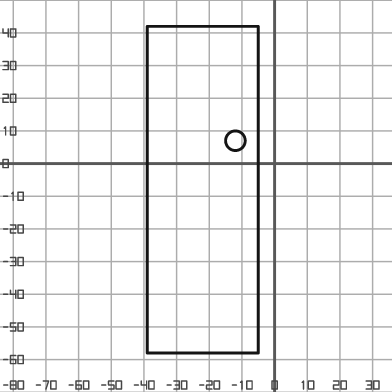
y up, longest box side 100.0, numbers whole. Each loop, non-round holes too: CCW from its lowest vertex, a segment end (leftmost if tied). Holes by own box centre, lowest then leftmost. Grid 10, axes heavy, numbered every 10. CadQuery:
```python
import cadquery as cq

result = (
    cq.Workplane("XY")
    .moveTo(-39.0, -58.0)
    .lineTo(-5.0, -58.0)
    .lineTo(-5.0, 42.0)
    .lineTo(-39.0, 42.0)
    .close()
    .moveTo(-12.0, 7.0)
    .circle(3.0)
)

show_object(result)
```